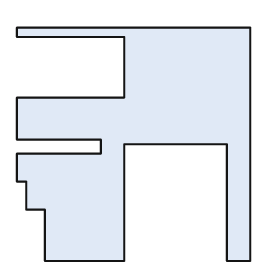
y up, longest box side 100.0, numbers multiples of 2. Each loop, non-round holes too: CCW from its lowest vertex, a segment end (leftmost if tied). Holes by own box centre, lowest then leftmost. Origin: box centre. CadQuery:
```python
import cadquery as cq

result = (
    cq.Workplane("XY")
    .moveTo(-38.0, -50.0)
    .lineTo(-4.0, -50.0)
    .lineTo(-4.0, 0.0)
    .lineTo(40.0, 0.0)
    .lineTo(40.0, -50.0)
    .lineTo(50.0, -50.0)
    .lineTo(50.0, 50.0)
    .lineTo(-50.0, 50.0)
    .lineTo(-50.0, 46.0)
    .lineTo(-4.0, 46.0)
    .lineTo(-4.0, 20.0)
    .lineTo(-50.0, 20.0)
    .lineTo(-50.0, 2.0)
    .lineTo(-14.0, 2.0)
    .lineTo(-14.0, -4.0)
    .lineTo(-50.0, -4.0)
    .lineTo(-50.0, -16.0)
    .lineTo(-46.0, -16.0)
    .lineTo(-46.0, -28.0)
    .lineTo(-38.0, -28.0)
    .close()
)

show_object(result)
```